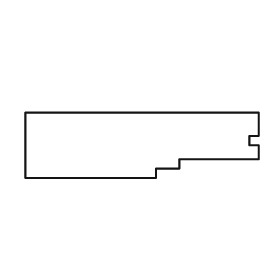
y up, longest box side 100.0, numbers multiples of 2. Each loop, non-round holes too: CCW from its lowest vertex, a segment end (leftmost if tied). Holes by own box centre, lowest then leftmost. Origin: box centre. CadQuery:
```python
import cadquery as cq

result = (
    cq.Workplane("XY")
    .moveTo(-50.0, -14.0)
    .lineTo(6.0, -14.0)
    .lineTo(6.0, -10.0)
    .lineTo(16.0, -10.0)
    .lineTo(16.0, -6.0)
    .lineTo(50.0, -6.0)
    .lineTo(50.0, 0.0)
    .lineTo(46.0, 0.0)
    .lineTo(46.0, 4.0)
    .lineTo(50.0, 4.0)
    .lineTo(50.0, 14.0)
    .lineTo(-50.0, 14.0)
    .close()
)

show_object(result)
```